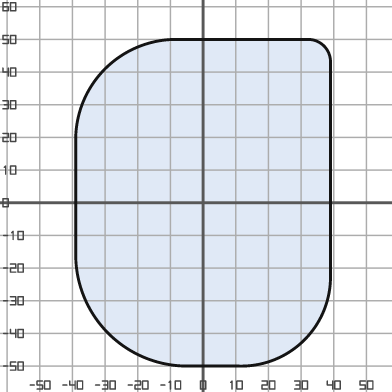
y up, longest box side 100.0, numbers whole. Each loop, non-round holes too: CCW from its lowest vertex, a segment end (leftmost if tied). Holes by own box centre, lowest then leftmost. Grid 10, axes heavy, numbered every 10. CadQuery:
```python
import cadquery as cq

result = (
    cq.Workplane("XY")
    .moveTo(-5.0, -50.0)
    .lineTo(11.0, -50.0)
    .threePointArc((31.0, -42.0), (39.0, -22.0))
    .lineTo(39.0, 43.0)
    .threePointArc((37.0, 48.0), (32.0, 50.0))
    .lineTo(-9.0, 50.0)
    .threePointArc((-30.0, 41.0), (-39.0, 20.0))
    .lineTo(-39.0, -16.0)
    .threePointArc((-29.0, -40.0), (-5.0, -50.0))
    .close()
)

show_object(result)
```